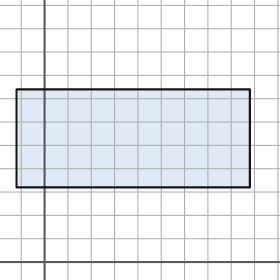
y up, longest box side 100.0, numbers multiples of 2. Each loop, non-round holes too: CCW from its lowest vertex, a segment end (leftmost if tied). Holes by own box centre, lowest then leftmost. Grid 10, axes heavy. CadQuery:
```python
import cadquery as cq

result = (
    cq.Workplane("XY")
    .moveTo(-12.0, 32.0)
    .lineTo(88.0, 32.0)
    .lineTo(88.0, 74.0)
    .lineTo(-12.0, 74.0)
    .close()
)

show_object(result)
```